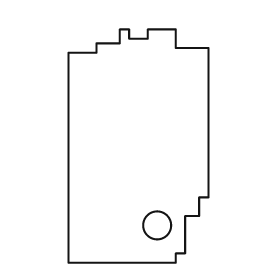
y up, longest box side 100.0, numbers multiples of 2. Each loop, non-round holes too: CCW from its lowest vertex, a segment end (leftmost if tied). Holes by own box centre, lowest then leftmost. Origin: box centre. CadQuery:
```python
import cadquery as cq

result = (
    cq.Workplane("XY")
    .moveTo(-30.0, -50.0)
    .lineTo(16.0, -50.0)
    .lineTo(16.0, -46.0)
    .lineTo(20.0, -46.0)
    .lineTo(20.0, -30.0)
    .lineTo(26.0, -30.0)
    .lineTo(26.0, -22.0)
    .lineTo(30.0, -22.0)
    .lineTo(30.0, 42.0)
    .lineTo(16.0, 42.0)
    .lineTo(16.0, 50.0)
    .lineTo(4.0, 50.0)
    .lineTo(4.0, 46.0)
    .lineTo(-4.0, 46.0)
    .lineTo(-4.0, 50.0)
    .lineTo(-8.0, 50.0)
    .lineTo(-8.0, 44.0)
    .lineTo(-18.0, 44.0)
    .lineTo(-18.0, 40.0)
    .lineTo(-30.0, 40.0)
    .close()
    .moveTo(8.0, -34.0)
    .circle(6.0)
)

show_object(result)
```